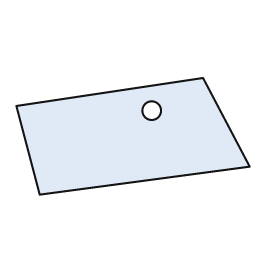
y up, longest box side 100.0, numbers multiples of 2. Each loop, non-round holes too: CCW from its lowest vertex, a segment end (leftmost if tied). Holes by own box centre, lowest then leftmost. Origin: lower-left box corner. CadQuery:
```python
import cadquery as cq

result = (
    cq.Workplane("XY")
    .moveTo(10.0, 0.0)
    .lineTo(100.0, 12.0)
    .lineTo(80.0, 50.0)
    .lineTo(0.0, 38.0)
    .close()
    .moveTo(58.0, 36.0)
    .circle(4.0)
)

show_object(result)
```